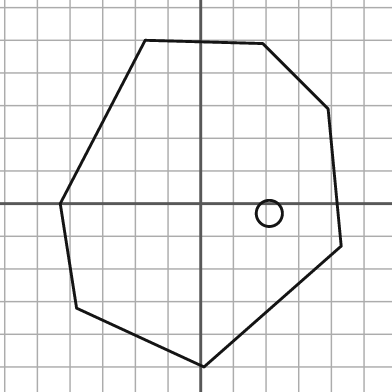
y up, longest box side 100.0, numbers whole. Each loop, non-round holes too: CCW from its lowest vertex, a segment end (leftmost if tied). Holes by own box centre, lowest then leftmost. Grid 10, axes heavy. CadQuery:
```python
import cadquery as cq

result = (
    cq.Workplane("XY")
    .moveTo(1.0, -50.0)
    .lineTo(43.0, -13.0)
    .lineTo(39.0, 29.0)
    .lineTo(19.0, 49.0)
    .lineTo(-17.0, 50.0)
    .lineTo(-43.0, 0.0)
    .lineTo(-38.0, -32.0)
    .close()
    .moveTo(21.0, -3.0)
    .circle(4.0)
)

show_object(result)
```